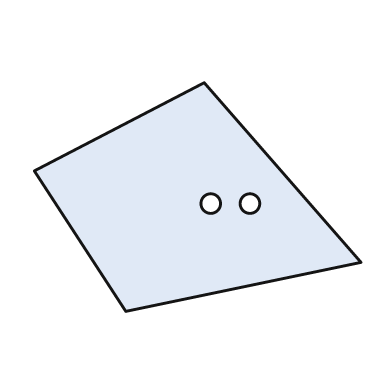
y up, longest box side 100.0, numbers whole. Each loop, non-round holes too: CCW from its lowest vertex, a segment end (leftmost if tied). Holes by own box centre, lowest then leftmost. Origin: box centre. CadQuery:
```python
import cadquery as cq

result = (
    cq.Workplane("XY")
    .moveTo(-22.0, -35.0)
    .lineTo(50.0, -20.0)
    .lineTo(2.0, 35.0)
    .lineTo(-50.0, 8.0)
    .close()
    .moveTo(4.0, -2.0)
    .circle(3.0)
    .moveTo(16.0, -2.0)
    .circle(3.0)
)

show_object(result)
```